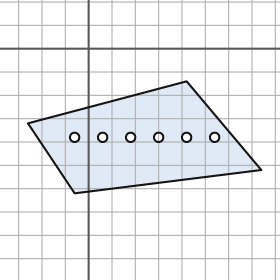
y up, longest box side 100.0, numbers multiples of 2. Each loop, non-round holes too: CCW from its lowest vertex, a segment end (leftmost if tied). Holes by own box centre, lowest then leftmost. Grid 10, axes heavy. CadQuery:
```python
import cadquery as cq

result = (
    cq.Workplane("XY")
    .moveTo(-6.0, -62.0)
    .lineTo(74.0, -52.0)
    .lineTo(42.0, -14.0)
    .lineTo(-26.0, -32.0)
    .close()
    .moveTo(-6.0, -38.0)
    .circle(2.0)
    .moveTo(6.0, -38.0)
    .circle(2.0)
    .moveTo(18.0, -38.0)
    .circle(2.0)
    .moveTo(30.0, -38.0)
    .circle(2.0)
    .moveTo(42.0, -38.0)
    .circle(2.0)
    .moveTo(54.0, -38.0)
    .circle(2.0)
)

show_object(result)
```